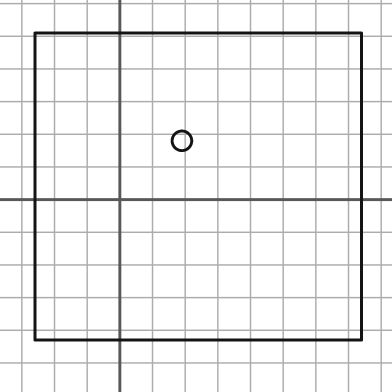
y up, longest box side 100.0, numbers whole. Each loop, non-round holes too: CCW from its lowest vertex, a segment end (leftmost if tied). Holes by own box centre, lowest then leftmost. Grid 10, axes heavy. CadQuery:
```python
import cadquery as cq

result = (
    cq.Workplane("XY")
    .moveTo(-26.0, -43.0)
    .lineTo(74.0, -43.0)
    .lineTo(74.0, 51.0)
    .lineTo(-26.0, 51.0)
    .close()
    .moveTo(19.0, 18.0)
    .circle(3.0)
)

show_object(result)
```